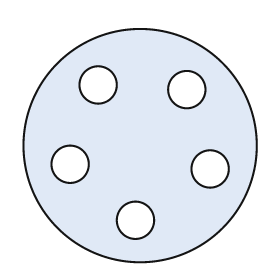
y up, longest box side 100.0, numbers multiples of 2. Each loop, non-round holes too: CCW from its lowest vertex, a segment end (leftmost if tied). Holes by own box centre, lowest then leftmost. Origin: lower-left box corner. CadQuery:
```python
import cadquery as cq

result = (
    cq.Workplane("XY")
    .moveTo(50.0, 50.0)
    .circle(50.0)
    .moveTo(48.0, 18.0)
    .circle(8.0)
    .moveTo(80.0, 40.0)
    .circle(8.0)
    .moveTo(20.0, 42.0)
    .circle(8.0)
    .moveTo(70.0, 74.0)
    .circle(8.0)
    .moveTo(32.0, 76.0)
    .circle(8.0)
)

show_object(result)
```